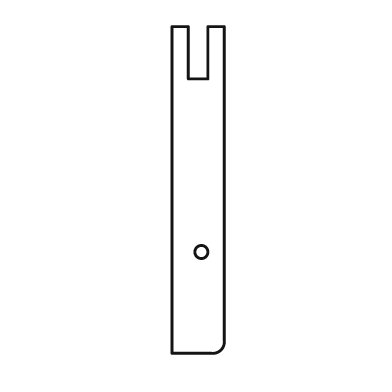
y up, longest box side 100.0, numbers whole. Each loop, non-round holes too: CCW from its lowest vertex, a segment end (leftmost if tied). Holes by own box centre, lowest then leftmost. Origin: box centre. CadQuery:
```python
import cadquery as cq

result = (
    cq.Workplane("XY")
    .moveTo(-8.0, -50.0)
    .lineTo(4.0, -50.0)
    .threePointArc((7.0, -49.0), (8.0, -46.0))
    .lineTo(8.0, 50.0)
    .lineTo(3.0, 50.0)
    .lineTo(3.0, 34.0)
    .lineTo(-3.0, 34.0)
    .lineTo(-3.0, 50.0)
    .lineTo(-8.0, 50.0)
    .close()
    .moveTo(1.0, -19.0)
    .circle(2.0)
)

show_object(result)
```